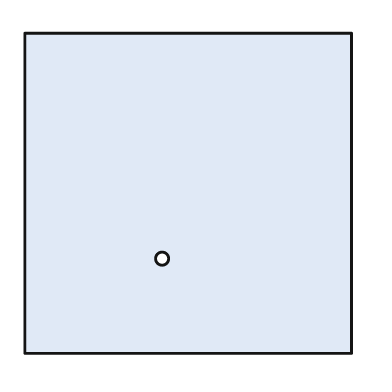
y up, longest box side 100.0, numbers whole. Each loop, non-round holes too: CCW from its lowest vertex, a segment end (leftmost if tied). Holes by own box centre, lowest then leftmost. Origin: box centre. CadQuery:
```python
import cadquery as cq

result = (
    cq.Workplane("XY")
    .moveTo(-50.0, -49.0)
    .lineTo(50.0, -49.0)
    .lineTo(50.0, 49.0)
    .lineTo(-50.0, 49.0)
    .close()
    .moveTo(-8.0, -20.0)
    .circle(2.0)
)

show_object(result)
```